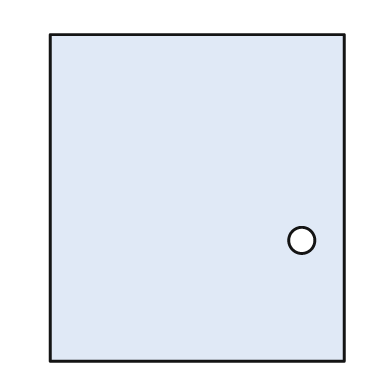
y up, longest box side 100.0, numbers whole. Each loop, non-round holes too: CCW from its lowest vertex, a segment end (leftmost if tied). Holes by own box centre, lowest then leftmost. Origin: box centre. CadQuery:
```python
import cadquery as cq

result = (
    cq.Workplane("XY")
    .moveTo(-45.0, -50.0)
    .lineTo(45.0, -50.0)
    .lineTo(45.0, 50.0)
    .lineTo(-45.0, 50.0)
    .close()
    .moveTo(32.0, -13.0)
    .circle(4.0)
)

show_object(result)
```